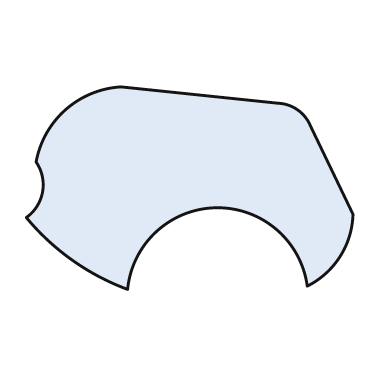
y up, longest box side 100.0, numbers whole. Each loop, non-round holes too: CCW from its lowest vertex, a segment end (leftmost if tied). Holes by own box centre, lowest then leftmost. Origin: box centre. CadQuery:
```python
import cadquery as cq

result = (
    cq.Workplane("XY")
    .moveTo(-19.0, -31.0)
    .threePointArc((8.0, -6.0), (36.0, -30.0))
    .threePointArc((46.0, -21.0), (50.0, -8.0))
    .lineTo(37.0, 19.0)
    .threePointArc((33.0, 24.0), (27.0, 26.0))
    .lineTo(-21.0, 31.0)
    .threePointArc((-38.0, 24.0), (-47.0, 8.0))
    .threePointArc((-45.0, -1.0), (-50.0, -9.0))
    .threePointArc((-36.0, -22.0), (-19.0, -31.0))
    .close()
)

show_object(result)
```